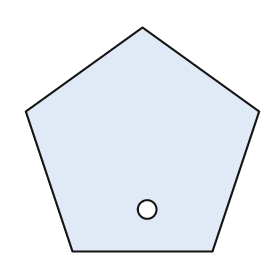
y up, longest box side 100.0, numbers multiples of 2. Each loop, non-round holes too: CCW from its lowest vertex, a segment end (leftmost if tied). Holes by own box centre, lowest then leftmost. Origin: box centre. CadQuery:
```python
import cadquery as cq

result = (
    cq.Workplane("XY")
    .moveTo(-30.0, -48.0)
    .lineTo(30.0, -48.0)
    .lineTo(50.0, 12.0)
    .lineTo(0.0, 48.0)
    .lineTo(-50.0, 12.0)
    .close()
    .moveTo(2.0, -30.0)
    .circle(4.0)
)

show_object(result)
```